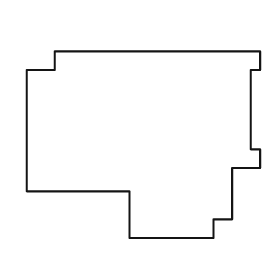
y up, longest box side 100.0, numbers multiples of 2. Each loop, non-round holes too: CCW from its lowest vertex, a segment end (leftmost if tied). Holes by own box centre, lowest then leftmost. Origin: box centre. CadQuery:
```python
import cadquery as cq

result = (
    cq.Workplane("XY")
    .moveTo(-6.0, -40.0)
    .lineTo(30.0, -40.0)
    .lineTo(30.0, -32.0)
    .lineTo(38.0, -32.0)
    .lineTo(38.0, -10.0)
    .lineTo(50.0, -10.0)
    .lineTo(50.0, -2.0)
    .lineTo(46.0, -2.0)
    .lineTo(46.0, 32.0)
    .lineTo(50.0, 32.0)
    .lineTo(50.0, 40.0)
    .lineTo(-38.0, 40.0)
    .lineTo(-38.0, 32.0)
    .lineTo(-50.0, 32.0)
    .lineTo(-50.0, -20.0)
    .lineTo(-6.0, -20.0)
    .close()
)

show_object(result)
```